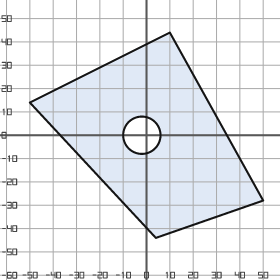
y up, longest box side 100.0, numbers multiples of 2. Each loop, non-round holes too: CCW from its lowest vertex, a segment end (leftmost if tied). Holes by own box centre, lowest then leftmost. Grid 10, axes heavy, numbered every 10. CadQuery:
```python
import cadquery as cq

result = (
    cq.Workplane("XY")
    .moveTo(4.0, -44.0)
    .lineTo(50.0, -28.0)
    .lineTo(10.0, 44.0)
    .lineTo(-50.0, 14.0)
    .close()
    .moveTo(-2.0, 0.0)
    .circle(8.0)
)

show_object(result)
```